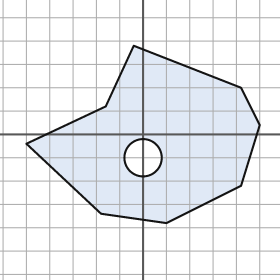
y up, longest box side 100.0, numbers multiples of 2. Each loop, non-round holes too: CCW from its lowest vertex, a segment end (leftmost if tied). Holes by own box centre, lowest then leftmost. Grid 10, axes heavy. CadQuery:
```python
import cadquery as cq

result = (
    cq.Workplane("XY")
    .moveTo(10.0, -38.0)
    .lineTo(42.0, -22.0)
    .lineTo(50.0, 4.0)
    .lineTo(42.0, 20.0)
    .lineTo(-4.0, 38.0)
    .lineTo(-16.0, 12.0)
    .lineTo(-50.0, -4.0)
    .lineTo(-18.0, -34.0)
    .close()
    .moveTo(0.0, -10.0)
    .circle(8.0)
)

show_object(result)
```